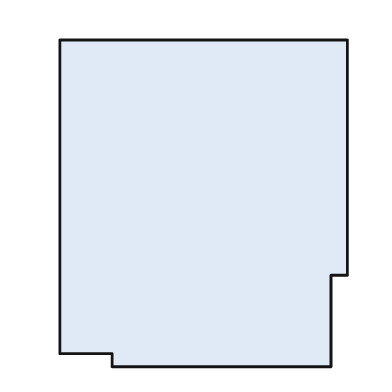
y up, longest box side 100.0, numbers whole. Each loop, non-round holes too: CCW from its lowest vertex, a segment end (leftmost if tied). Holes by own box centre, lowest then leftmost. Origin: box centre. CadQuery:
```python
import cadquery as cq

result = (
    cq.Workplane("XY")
    .moveTo(-28.0, -50.0)
    .lineTo(39.0, -50.0)
    .lineTo(39.0, -22.0)
    .lineTo(44.0, -22.0)
    .lineTo(44.0, 50.0)
    .lineTo(-44.0, 50.0)
    .lineTo(-44.0, -46.0)
    .lineTo(-28.0, -46.0)
    .close()
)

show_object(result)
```